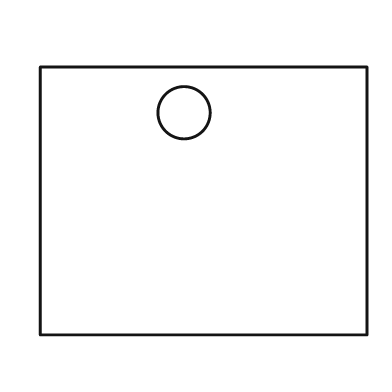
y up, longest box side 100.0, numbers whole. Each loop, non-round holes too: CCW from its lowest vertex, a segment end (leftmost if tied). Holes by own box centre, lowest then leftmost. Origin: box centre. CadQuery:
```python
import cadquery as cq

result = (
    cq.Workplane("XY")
    .moveTo(-50.0, -41.0)
    .lineTo(50.0, -41.0)
    .lineTo(50.0, 41.0)
    .lineTo(-50.0, 41.0)
    .close()
    .moveTo(-6.0, 27.0)
    .circle(8.0)
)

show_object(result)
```